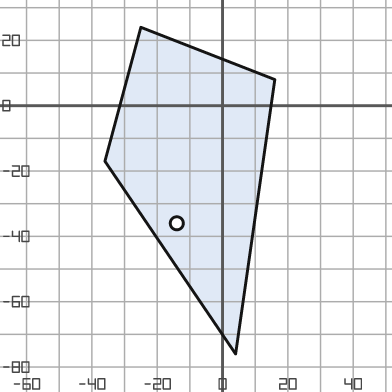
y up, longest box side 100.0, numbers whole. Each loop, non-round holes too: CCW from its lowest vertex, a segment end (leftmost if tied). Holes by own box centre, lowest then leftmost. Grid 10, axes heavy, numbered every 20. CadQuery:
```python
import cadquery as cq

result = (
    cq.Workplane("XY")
    .moveTo(4.0, -76.0)
    .lineTo(16.0, 8.0)
    .lineTo(-25.0, 24.0)
    .lineTo(-36.0, -17.0)
    .close()
    .moveTo(-14.0, -36.0)
    .circle(2.0)
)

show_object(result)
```